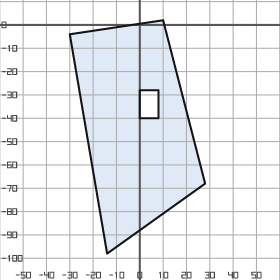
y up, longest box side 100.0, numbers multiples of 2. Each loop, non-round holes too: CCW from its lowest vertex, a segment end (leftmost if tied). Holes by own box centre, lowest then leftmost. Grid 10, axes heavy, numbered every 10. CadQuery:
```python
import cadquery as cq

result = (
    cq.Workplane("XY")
    .moveTo(-14.0, -98.0)
    .lineTo(28.0, -68.0)
    .lineTo(10.0, 2.0)
    .lineTo(-30.0, -4.0)
    .close()
    .moveTo(0.0, -40.0)
    .lineTo(8.0, -40.0)
    .lineTo(8.0, -28.0)
    .lineTo(0.0, -28.0)
    .close()
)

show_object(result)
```